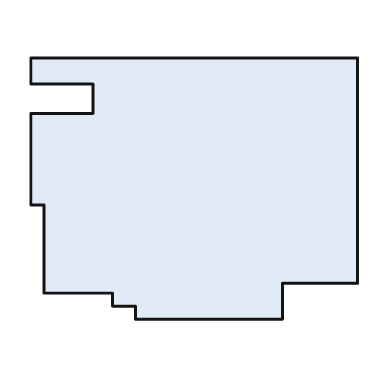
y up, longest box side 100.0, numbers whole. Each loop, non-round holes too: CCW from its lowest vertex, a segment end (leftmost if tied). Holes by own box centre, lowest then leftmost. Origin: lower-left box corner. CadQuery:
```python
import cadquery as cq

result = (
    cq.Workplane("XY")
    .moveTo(32.0, 0.0)
    .lineTo(77.0, 0.0)
    .lineTo(77.0, 11.0)
    .lineTo(100.0, 11.0)
    .lineTo(100.0, 80.0)
    .lineTo(0.0, 80.0)
    .lineTo(0.0, 72.0)
    .lineTo(19.0, 72.0)
    .lineTo(19.0, 63.0)
    .lineTo(0.0, 63.0)
    .lineTo(0.0, 35.0)
    .lineTo(4.0, 35.0)
    .lineTo(4.0, 8.0)
    .lineTo(25.0, 8.0)
    .lineTo(25.0, 4.0)
    .lineTo(32.0, 4.0)
    .close()
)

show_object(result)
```